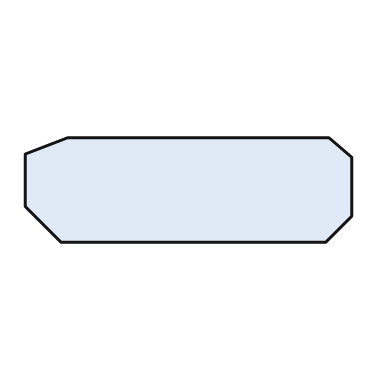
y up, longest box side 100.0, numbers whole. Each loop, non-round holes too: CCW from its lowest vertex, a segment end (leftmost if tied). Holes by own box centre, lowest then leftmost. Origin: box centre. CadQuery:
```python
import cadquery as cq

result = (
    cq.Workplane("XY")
    .moveTo(-39.0, -16.0)
    .lineTo(42.0, -16.0)
    .lineTo(50.0, -8.0)
    .lineTo(50.0, 10.0)
    .lineTo(43.0, 16.0)
    .lineTo(-37.0, 16.0)
    .lineTo(-50.0, 11.0)
    .lineTo(-50.0, -5.0)
    .close()
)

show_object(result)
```